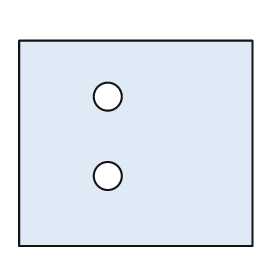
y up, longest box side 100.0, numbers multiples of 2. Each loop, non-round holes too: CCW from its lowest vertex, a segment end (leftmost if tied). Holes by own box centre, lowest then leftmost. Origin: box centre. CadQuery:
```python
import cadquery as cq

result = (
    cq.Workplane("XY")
    .moveTo(-50.0, -44.0)
    .lineTo(50.0, -44.0)
    .lineTo(50.0, 44.0)
    .lineTo(-50.0, 44.0)
    .close()
    .moveTo(-12.0, -14.0)
    .circle(6.0)
    .moveTo(-12.0, 20.0)
    .circle(6.0)
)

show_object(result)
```